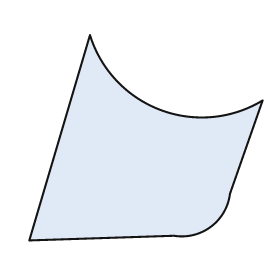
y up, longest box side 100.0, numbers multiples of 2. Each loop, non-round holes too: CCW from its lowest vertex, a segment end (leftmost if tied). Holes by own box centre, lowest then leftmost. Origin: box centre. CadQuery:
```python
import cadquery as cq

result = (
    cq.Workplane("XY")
    .moveTo(-50.0, -44.0)
    .lineTo(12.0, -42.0)
    .threePointArc((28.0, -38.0), (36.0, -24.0))
    .lineTo(50.0, 16.0)
    .threePointArc((6.0, 12.0), (-24.0, 44.0))
    .close()
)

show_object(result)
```